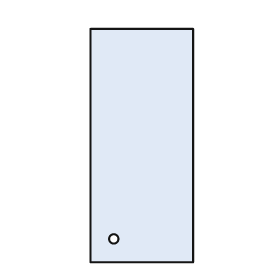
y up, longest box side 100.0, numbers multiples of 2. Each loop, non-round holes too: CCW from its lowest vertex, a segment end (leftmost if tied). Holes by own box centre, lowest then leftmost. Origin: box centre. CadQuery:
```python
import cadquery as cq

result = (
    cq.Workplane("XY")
    .moveTo(-22.0, -50.0)
    .lineTo(22.0, -50.0)
    .lineTo(22.0, 50.0)
    .lineTo(-22.0, 50.0)
    .close()
    .moveTo(-12.0, -40.0)
    .circle(2.0)
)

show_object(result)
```